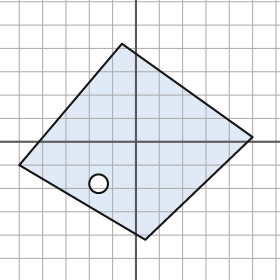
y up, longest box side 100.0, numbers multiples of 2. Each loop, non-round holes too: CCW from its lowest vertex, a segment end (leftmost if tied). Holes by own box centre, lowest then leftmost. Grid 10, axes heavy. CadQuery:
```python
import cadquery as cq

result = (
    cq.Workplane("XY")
    .moveTo(4.0, -42.0)
    .lineTo(50.0, 2.0)
    .lineTo(-6.0, 42.0)
    .lineTo(-50.0, -10.0)
    .close()
    .moveTo(-16.0, -18.0)
    .circle(4.0)
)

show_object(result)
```